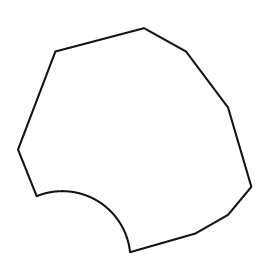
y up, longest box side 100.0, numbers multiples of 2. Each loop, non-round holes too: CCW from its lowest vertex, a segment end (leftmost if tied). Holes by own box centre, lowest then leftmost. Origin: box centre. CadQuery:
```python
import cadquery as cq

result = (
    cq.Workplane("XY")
    .moveTo(-2.0, -48.0)
    .lineTo(26.0, -40.0)
    .lineTo(40.0, -32.0)
    .lineTo(50.0, -20.0)
    .lineTo(40.0, 14.0)
    .lineTo(22.0, 38.0)
    .lineTo(4.0, 48.0)
    .lineTo(-34.0, 38.0)
    .lineTo(-50.0, -4.0)
    .lineTo(-42.0, -24.0)
    .threePointArc((-16.0, -26.0), (-2.0, -48.0))
    .close()
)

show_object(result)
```